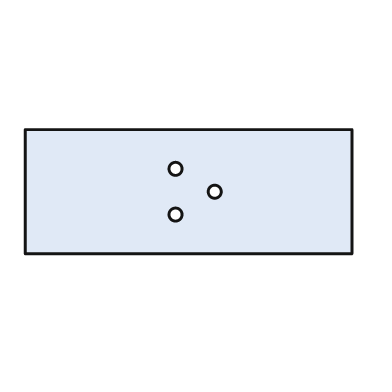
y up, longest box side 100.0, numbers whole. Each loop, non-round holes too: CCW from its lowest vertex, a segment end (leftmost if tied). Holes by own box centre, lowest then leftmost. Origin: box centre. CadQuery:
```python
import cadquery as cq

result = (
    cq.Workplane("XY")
    .moveTo(-50.0, -19.0)
    .lineTo(50.0, -19.0)
    .lineTo(50.0, 19.0)
    .lineTo(-50.0, 19.0)
    .close()
    .moveTo(-4.0, -7.0)
    .circle(2.0)
    .moveTo(8.0, 0.0)
    .circle(2.0)
    .moveTo(-4.0, 7.0)
    .circle(2.0)
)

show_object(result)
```